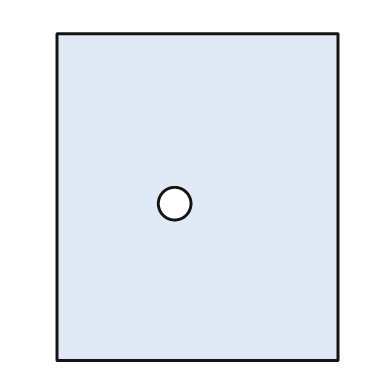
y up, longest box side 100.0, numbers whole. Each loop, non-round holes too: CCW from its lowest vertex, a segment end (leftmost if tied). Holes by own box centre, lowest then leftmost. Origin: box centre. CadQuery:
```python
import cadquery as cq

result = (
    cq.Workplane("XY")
    .moveTo(-43.0, -50.0)
    .lineTo(43.0, -50.0)
    .lineTo(43.0, 50.0)
    .lineTo(-43.0, 50.0)
    .close()
    .moveTo(-7.0, -2.0)
    .circle(5.0)
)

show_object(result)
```